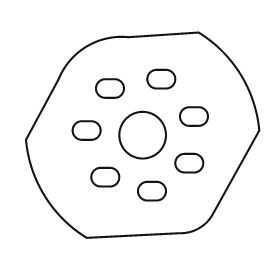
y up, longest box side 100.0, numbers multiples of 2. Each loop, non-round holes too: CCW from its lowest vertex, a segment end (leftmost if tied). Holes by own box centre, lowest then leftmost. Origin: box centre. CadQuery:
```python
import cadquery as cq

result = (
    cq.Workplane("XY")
    .moveTo(-24.0, -44.0)
    .lineTo(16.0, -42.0)
    .threePointArc((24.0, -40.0), (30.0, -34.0))
    .lineTo(50.0, 2.0)
    .threePointArc((42.0, 26.0), (24.0, 44.0))
    .lineTo(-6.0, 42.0)
    .threePointArc((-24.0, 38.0), (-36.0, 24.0))
    .lineTo(-50.0, -2.0)
    .threePointArc((-42.0, -26.0), (-24.0, -44.0))
    .close()
    .moveTo(2.0, -28.0)
    .lineTo(6.0, -28.0)
    .threePointArc((10.0, -24.0), (6.0, -20.0))
    .lineTo(2.0, -20.0)
    .threePointArc((-2.0, -24.0), (2.0, -28.0))
    .close()
    .moveTo(-18.0, -22.0)
    .lineTo(-14.0, -22.0)
    .threePointArc((-10.0, -18.0), (-14.0, -14.0))
    .lineTo(-18.0, -14.0)
    .threePointArc((-22.0, -18.0), (-18.0, -22.0))
    .close()
    .moveTo(18.0, -16.0)
    .lineTo(22.0, -16.0)
    .threePointArc((26.0, -12.0), (22.0, -8.0))
    .lineTo(18.0, -8.0)
    .threePointArc((14.0, -12.0), (18.0, -16.0))
    .close()
    .moveTo(0.0, 0.0)
    .circle(10.0)
    .moveTo(-26.0, -2.0)
    .lineTo(-22.0, -2.0)
    .threePointArc((-18.0, 2.0), (-22.0, 6.0))
    .lineTo(-26.0, 6.0)
    .threePointArc((-30.0, 2.0), (-26.0, -2.0))
    .close()
    .moveTo(20.0, 4.0)
    .lineTo(24.0, 4.0)
    .threePointArc((28.0, 8.0), (24.0, 12.0))
    .lineTo(20.0, 12.0)
    .threePointArc((16.0, 8.0), (20.0, 4.0))
    .close()
    .moveTo(-16.0, 16.0)
    .lineTo(-12.0, 16.0)
    .threePointArc((-8.0, 20.0), (-12.0, 24.0))
    .lineTo(-16.0, 24.0)
    .threePointArc((-20.0, 20.0), (-16.0, 16.0))
    .close()
    .moveTo(6.0, 20.0)
    .lineTo(10.0, 20.0)
    .threePointArc((14.0, 24.0), (10.0, 28.0))
    .lineTo(6.0, 28.0)
    .threePointArc((2.0, 24.0), (6.0, 20.0))
    .close()
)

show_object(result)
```